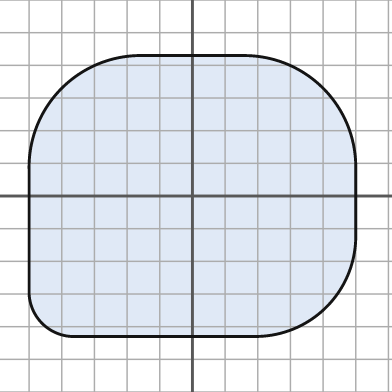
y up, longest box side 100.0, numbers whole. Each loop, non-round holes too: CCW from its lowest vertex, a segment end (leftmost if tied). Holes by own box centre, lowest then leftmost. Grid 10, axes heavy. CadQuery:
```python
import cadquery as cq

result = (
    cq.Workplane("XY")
    .moveTo(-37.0, -43.0)
    .lineTo(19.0, -43.0)
    .threePointArc((41.0, -34.0), (50.0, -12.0))
    .lineTo(50.0, 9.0)
    .threePointArc((40.0, 33.0), (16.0, 43.0))
    .lineTo(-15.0, 43.0)
    .threePointArc((-40.0, 33.0), (-50.0, 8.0))
    .lineTo(-50.0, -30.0)
    .threePointArc((-46.0, -39.0), (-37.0, -43.0))
    .close()
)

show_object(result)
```